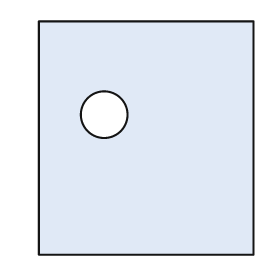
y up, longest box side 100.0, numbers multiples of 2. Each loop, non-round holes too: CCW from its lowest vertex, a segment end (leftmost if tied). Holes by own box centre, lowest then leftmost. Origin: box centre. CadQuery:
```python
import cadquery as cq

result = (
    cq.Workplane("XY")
    .moveTo(-46.0, -50.0)
    .lineTo(46.0, -50.0)
    .lineTo(46.0, 50.0)
    .lineTo(-46.0, 50.0)
    .close()
    .moveTo(-18.0, 10.0)
    .circle(10.0)
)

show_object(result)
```